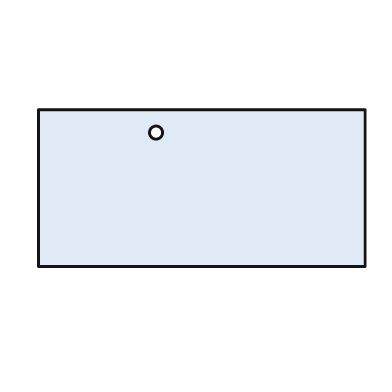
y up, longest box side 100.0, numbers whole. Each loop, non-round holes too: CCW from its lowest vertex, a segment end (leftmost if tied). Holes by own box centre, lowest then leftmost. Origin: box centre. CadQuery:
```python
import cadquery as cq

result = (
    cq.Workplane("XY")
    .moveTo(-50.0, -24.0)
    .lineTo(50.0, -24.0)
    .lineTo(50.0, 24.0)
    .lineTo(-50.0, 24.0)
    .close()
    .moveTo(-14.0, 17.0)
    .circle(2.0)
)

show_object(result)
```